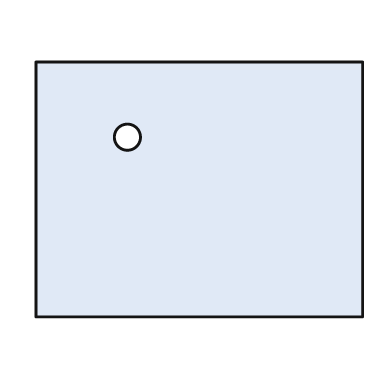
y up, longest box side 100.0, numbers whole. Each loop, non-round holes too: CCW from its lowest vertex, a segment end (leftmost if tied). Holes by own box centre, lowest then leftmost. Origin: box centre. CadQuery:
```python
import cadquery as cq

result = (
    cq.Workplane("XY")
    .moveTo(-50.0, -39.0)
    .lineTo(50.0, -39.0)
    .lineTo(50.0, 39.0)
    .lineTo(-50.0, 39.0)
    .close()
    .moveTo(-22.0, 16.0)
    .circle(4.0)
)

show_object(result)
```